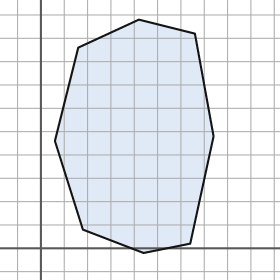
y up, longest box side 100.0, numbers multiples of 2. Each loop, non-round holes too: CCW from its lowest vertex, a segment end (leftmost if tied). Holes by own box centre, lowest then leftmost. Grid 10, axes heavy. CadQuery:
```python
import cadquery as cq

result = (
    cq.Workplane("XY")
    .moveTo(44.0, -2.0)
    .lineTo(64.0, 2.0)
    .lineTo(74.0, 48.0)
    .lineTo(66.0, 92.0)
    .lineTo(42.0, 98.0)
    .lineTo(16.0, 86.0)
    .lineTo(6.0, 46.0)
    .lineTo(18.0, 8.0)
    .close()
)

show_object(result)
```